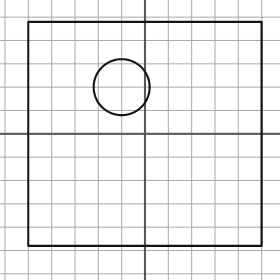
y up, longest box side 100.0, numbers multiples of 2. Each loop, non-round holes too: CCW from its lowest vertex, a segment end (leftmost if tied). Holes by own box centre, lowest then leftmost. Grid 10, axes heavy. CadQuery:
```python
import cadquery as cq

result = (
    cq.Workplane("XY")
    .moveTo(-50.0, -48.0)
    .lineTo(50.0, -48.0)
    .lineTo(50.0, 48.0)
    .lineTo(-50.0, 48.0)
    .close()
    .moveTo(-10.0, 20.0)
    .circle(12.0)
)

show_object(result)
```